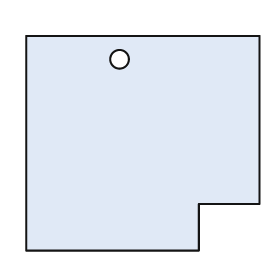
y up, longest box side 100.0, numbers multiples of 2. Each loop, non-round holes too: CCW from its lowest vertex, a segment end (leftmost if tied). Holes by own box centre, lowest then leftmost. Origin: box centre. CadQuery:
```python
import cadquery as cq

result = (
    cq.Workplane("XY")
    .moveTo(-50.0, -46.0)
    .lineTo(24.0, -46.0)
    .lineTo(24.0, -26.0)
    .lineTo(50.0, -26.0)
    .lineTo(50.0, 46.0)
    .lineTo(-50.0, 46.0)
    .close()
    .moveTo(-10.0, 36.0)
    .circle(4.0)
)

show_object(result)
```